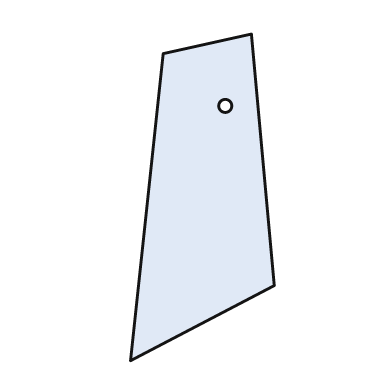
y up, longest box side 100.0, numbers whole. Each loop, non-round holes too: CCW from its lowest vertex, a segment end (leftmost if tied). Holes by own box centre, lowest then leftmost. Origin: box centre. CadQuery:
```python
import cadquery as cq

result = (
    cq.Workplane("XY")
    .moveTo(-22.0, -50.0)
    .lineTo(22.0, -27.0)
    .lineTo(15.0, 50.0)
    .lineTo(-12.0, 44.0)
    .close()
    .moveTo(7.0, 28.0)
    .circle(2.0)
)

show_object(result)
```